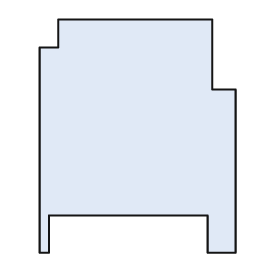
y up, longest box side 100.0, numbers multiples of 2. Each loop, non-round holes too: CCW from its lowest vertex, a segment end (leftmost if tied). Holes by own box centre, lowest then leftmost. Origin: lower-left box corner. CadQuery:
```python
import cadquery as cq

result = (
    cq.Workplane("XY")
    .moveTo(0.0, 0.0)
    .lineTo(4.0, 0.0)
    .lineTo(4.0, 16.0)
    .lineTo(72.0, 16.0)
    .lineTo(72.0, 0.0)
    .lineTo(84.0, 0.0)
    .lineTo(84.0, 70.0)
    .lineTo(74.0, 70.0)
    .lineTo(74.0, 100.0)
    .lineTo(8.0, 100.0)
    .lineTo(8.0, 88.0)
    .lineTo(0.0, 88.0)
    .close()
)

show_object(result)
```